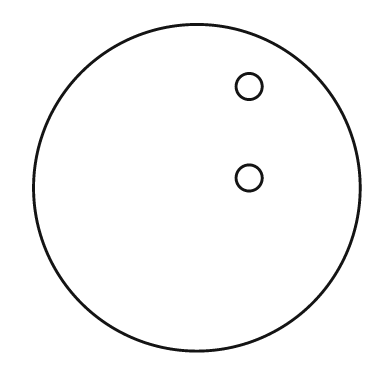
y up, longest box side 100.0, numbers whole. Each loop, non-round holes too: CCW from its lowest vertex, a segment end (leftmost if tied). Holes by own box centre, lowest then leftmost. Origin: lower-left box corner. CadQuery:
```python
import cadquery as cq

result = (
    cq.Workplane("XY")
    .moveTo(50.0, 50.0)
    .circle(50.0)
    .moveTo(66.0, 53.0)
    .circle(4.0)
    .moveTo(66.0, 81.0)
    .circle(4.0)
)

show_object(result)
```